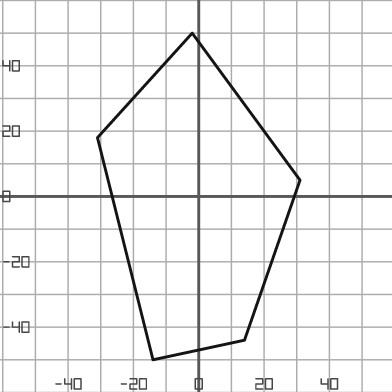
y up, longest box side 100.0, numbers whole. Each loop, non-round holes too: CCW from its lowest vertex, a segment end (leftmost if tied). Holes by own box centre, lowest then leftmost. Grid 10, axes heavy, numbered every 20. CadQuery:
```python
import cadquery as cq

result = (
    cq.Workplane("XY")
    .moveTo(-14.0, -50.0)
    .lineTo(14.0, -44.0)
    .lineTo(31.0, 5.0)
    .lineTo(-2.0, 50.0)
    .lineTo(-31.0, 18.0)
    .close()
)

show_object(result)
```